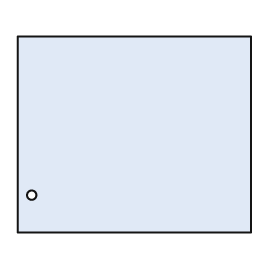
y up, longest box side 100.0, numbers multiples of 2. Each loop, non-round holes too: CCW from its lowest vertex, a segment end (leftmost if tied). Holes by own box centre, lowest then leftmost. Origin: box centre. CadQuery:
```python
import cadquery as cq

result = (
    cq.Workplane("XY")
    .moveTo(-50.0, -42.0)
    .lineTo(50.0, -42.0)
    .lineTo(50.0, 42.0)
    .lineTo(-50.0, 42.0)
    .close()
    .moveTo(-44.0, -26.0)
    .circle(2.0)
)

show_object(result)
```